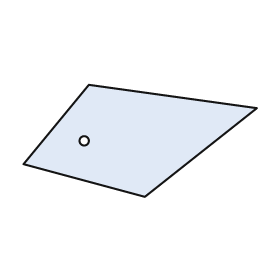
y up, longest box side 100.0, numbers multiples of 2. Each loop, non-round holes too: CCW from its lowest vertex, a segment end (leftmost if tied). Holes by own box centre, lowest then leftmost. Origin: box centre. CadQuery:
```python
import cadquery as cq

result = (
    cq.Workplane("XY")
    .moveTo(2.0, -24.0)
    .lineTo(50.0, 14.0)
    .lineTo(-22.0, 24.0)
    .lineTo(-50.0, -10.0)
    .close()
    .moveTo(-24.0, 0.0)
    .circle(2.0)
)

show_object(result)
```